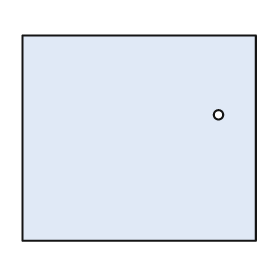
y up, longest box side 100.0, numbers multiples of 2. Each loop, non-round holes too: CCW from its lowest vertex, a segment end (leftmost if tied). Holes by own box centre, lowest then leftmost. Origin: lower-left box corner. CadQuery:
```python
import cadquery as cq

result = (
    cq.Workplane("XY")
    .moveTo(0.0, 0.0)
    .lineTo(100.0, 0.0)
    .lineTo(100.0, 88.0)
    .lineTo(0.0, 88.0)
    .close()
    .moveTo(84.0, 54.0)
    .circle(2.0)
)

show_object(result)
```